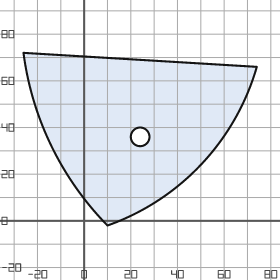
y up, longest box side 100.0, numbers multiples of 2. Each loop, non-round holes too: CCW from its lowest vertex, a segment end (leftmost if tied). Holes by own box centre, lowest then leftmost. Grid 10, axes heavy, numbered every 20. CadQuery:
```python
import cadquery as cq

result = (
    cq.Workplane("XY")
    .moveTo(10.0, -2.0)
    .threePointArc((50.0, 24.0), (74.0, 66.0))
    .lineTo(-26.0, 72.0)
    .threePointArc((-14.0, 32.0), (10.0, -2.0))
    .close()
    .moveTo(24.0, 36.0)
    .circle(4.0)
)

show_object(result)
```